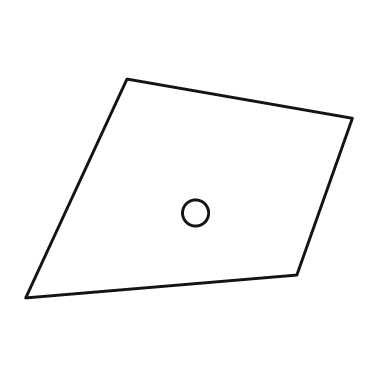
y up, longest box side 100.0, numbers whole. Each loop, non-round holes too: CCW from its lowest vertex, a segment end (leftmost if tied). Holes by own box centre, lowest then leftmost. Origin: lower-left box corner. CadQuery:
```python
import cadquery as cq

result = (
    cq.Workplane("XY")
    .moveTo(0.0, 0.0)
    .lineTo(83.0, 7.0)
    .lineTo(100.0, 55.0)
    .lineTo(31.0, 67.0)
    .close()
    .moveTo(52.0, 26.0)
    .circle(4.0)
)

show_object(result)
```